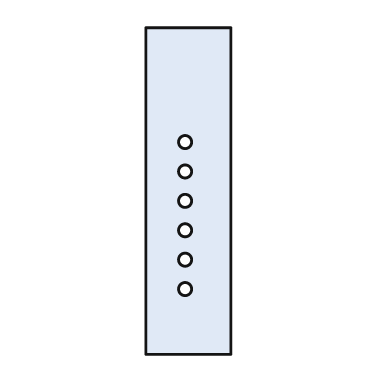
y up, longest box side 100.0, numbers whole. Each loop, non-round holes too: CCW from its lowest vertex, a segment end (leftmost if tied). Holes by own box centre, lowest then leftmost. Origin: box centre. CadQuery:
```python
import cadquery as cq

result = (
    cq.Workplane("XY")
    .moveTo(-13.0, -50.0)
    .lineTo(13.0, -50.0)
    .lineTo(13.0, 50.0)
    .lineTo(-13.0, 50.0)
    .close()
    .moveTo(-1.0, -30.0)
    .circle(2.0)
    .moveTo(-1.0, -21.0)
    .circle(2.0)
    .moveTo(-1.0, -12.0)
    .circle(2.0)
    .moveTo(-1.0, -3.0)
    .circle(2.0)
    .moveTo(-1.0, 6.0)
    .circle(2.0)
    .moveTo(-1.0, 15.0)
    .circle(2.0)
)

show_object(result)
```